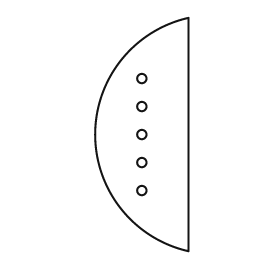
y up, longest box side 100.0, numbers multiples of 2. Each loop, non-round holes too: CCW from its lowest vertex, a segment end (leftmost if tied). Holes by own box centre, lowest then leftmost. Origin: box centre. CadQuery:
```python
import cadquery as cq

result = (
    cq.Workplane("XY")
    .moveTo(20.0, -50.0)
    .lineTo(20.0, 50.0)
    .threePointArc((-20.0, 0.0), (20.0, -50.0))
    .close()
    .moveTo(0.0, -24.0)
    .circle(2.0)
    .moveTo(0.0, -12.0)
    .circle(2.0)
    .moveTo(0.0, 0.0)
    .circle(2.0)
    .moveTo(0.0, 12.0)
    .circle(2.0)
    .moveTo(0.0, 24.0)
    .circle(2.0)
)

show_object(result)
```